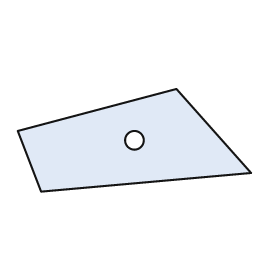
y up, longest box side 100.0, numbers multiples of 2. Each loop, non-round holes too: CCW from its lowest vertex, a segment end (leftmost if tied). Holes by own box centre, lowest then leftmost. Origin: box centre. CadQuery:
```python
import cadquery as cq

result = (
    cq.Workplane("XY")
    .moveTo(-40.0, -22.0)
    .lineTo(50.0, -14.0)
    .lineTo(18.0, 22.0)
    .lineTo(-50.0, 4.0)
    .close()
    .moveTo(0.0, 0.0)
    .circle(4.0)
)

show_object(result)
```